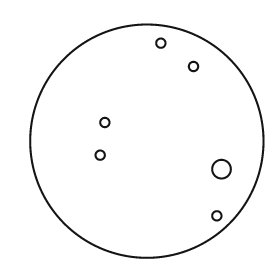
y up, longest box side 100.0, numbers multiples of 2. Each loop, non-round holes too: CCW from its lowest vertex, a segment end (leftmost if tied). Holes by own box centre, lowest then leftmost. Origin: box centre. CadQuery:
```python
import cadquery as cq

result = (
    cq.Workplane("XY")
    .moveTo(0.0, 0.0)
    .circle(50.0)
    .moveTo(30.0, -32.0)
    .circle(2.0)
    .moveTo(32.0, -12.0)
    .circle(4.0)
    .moveTo(-20.0, -6.0)
    .circle(2.0)
    .moveTo(-18.0, 8.0)
    .circle(2.0)
    .moveTo(20.0, 32.0)
    .circle(2.0)
    .moveTo(6.0, 42.0)
    .circle(2.0)
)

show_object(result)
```